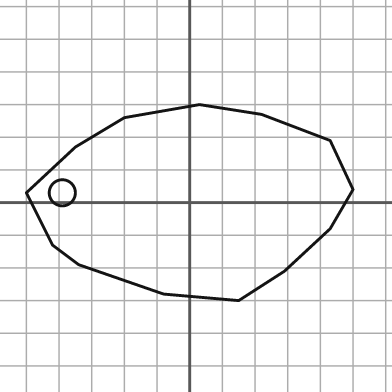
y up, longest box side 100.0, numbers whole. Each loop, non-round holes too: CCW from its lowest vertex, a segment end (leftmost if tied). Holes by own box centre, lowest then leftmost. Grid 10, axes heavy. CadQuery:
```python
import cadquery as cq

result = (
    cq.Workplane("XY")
    .moveTo(15.0, -30.0)
    .lineTo(29.0, -21.0)
    .lineTo(43.0, -8.0)
    .lineTo(50.0, 4.0)
    .lineTo(43.0, 19.0)
    .lineTo(22.0, 27.0)
    .lineTo(3.0, 30.0)
    .lineTo(-20.0, 26.0)
    .lineTo(-35.0, 17.0)
    .lineTo(-50.0, 3.0)
    .lineTo(-42.0, -13.0)
    .lineTo(-34.0, -19.0)
    .lineTo(-8.0, -28.0)
    .close()
    .moveTo(-39.0, 3.0)
    .circle(4.0)
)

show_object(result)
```